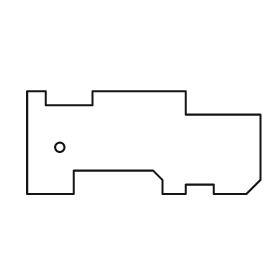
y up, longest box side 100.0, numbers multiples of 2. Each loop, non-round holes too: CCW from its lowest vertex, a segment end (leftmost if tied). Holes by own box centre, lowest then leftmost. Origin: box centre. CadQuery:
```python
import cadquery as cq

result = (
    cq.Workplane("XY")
    .moveTo(-50.0, -22.0)
    .lineTo(-30.0, -22.0)
    .lineTo(-30.0, -12.0)
    .lineTo(4.0, -12.0)
    .lineTo(8.0, -16.0)
    .lineTo(8.0, -22.0)
    .lineTo(18.0, -22.0)
    .lineTo(18.0, -18.0)
    .lineTo(30.0, -18.0)
    .lineTo(30.0, -22.0)
    .lineTo(44.0, -22.0)
    .lineTo(50.0, -16.0)
    .lineTo(50.0, 12.0)
    .lineTo(18.0, 12.0)
    .lineTo(18.0, 22.0)
    .lineTo(-22.0, 22.0)
    .lineTo(-22.0, 16.0)
    .lineTo(-42.0, 16.0)
    .lineTo(-42.0, 22.0)
    .lineTo(-50.0, 22.0)
    .close()
    .moveTo(-36.0, -2.0)
    .circle(2.0)
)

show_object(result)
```